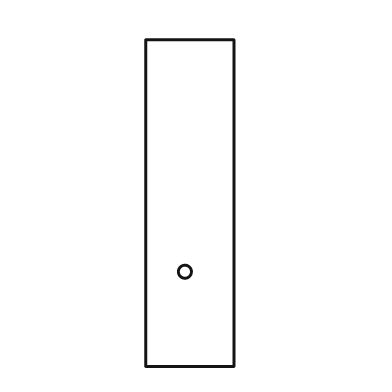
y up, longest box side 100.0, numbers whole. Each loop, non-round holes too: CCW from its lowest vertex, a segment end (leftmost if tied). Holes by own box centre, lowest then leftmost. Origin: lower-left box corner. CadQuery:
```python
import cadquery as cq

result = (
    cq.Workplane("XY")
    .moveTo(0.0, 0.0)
    .lineTo(27.0, 0.0)
    .lineTo(27.0, 100.0)
    .lineTo(0.0, 100.0)
    .close()
    .moveTo(12.0, 29.0)
    .circle(2.0)
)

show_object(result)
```